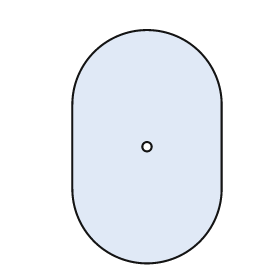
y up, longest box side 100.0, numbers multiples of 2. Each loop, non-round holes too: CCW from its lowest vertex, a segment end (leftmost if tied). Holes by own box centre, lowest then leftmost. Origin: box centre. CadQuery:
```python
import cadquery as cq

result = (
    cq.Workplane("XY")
    .moveTo(-32.0, -18.0)
    .threePointArc((0.0, -50.0), (32.0, -18.0))
    .lineTo(32.0, 18.0)
    .threePointArc((0.0, 50.0), (-32.0, 18.0))
    .close()
    .moveTo(0.0, 0.0)
    .circle(2.0)
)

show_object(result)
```